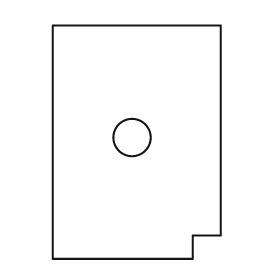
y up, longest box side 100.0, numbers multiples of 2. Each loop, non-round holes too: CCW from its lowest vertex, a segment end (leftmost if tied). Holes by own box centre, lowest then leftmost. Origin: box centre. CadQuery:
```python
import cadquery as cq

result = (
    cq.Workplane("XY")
    .moveTo(-36.0, -50.0)
    .lineTo(24.0, -50.0)
    .lineTo(24.0, -40.0)
    .lineTo(36.0, -40.0)
    .lineTo(36.0, 50.0)
    .lineTo(-36.0, 50.0)
    .close()
    .moveTo(-2.0, 2.0)
    .circle(8.0)
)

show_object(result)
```